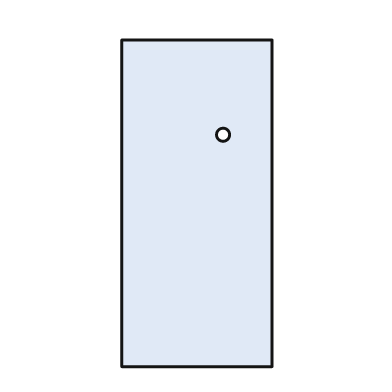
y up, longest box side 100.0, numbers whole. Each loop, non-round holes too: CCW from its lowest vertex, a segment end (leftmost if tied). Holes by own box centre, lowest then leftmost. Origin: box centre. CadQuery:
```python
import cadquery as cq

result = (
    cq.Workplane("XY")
    .moveTo(-23.0, -50.0)
    .lineTo(23.0, -50.0)
    .lineTo(23.0, 50.0)
    .lineTo(-23.0, 50.0)
    .close()
    .moveTo(8.0, 21.0)
    .circle(2.0)
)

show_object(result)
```